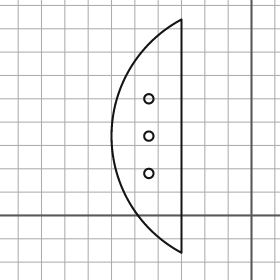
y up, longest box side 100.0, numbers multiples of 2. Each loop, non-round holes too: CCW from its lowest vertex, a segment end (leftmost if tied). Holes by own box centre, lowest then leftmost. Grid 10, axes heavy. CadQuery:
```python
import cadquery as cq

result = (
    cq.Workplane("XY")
    .moveTo(-30.0, -16.0)
    .lineTo(-30.0, 84.0)
    .threePointArc((-60.0, 34.0), (-30.0, -16.0))
    .close()
    .moveTo(-44.0, 18.0)
    .circle(2.0)
    .moveTo(-44.0, 34.0)
    .circle(2.0)
    .moveTo(-44.0, 50.0)
    .circle(2.0)
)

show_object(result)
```